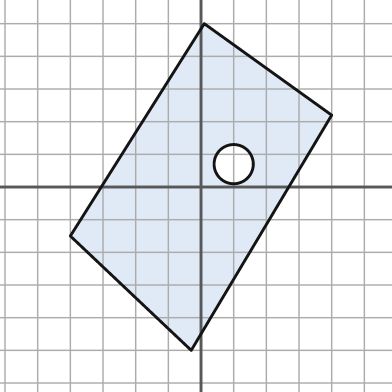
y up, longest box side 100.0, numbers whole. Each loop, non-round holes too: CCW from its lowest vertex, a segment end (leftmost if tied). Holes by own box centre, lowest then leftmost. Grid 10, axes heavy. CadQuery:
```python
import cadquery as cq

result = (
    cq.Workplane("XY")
    .moveTo(-3.0, -50.0)
    .lineTo(40.0, 22.0)
    .lineTo(1.0, 50.0)
    .lineTo(-40.0, -15.0)
    .close()
    .moveTo(10.0, 7.0)
    .circle(6.0)
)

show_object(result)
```